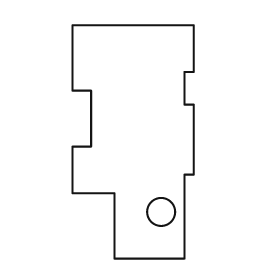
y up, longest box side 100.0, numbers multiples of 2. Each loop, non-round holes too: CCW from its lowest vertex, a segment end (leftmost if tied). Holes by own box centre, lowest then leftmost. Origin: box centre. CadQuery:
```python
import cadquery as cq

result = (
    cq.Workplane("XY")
    .moveTo(-8.0, -50.0)
    .lineTo(22.0, -50.0)
    .lineTo(22.0, -14.0)
    .lineTo(26.0, -14.0)
    .lineTo(26.0, 16.0)
    .lineTo(22.0, 16.0)
    .lineTo(22.0, 30.0)
    .lineTo(26.0, 30.0)
    .lineTo(26.0, 50.0)
    .lineTo(-26.0, 50.0)
    .lineTo(-26.0, 22.0)
    .lineTo(-18.0, 22.0)
    .lineTo(-18.0, -2.0)
    .lineTo(-26.0, -2.0)
    .lineTo(-26.0, -22.0)
    .lineTo(-8.0, -22.0)
    .close()
    .moveTo(12.0, -30.0)
    .circle(6.0)
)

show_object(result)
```